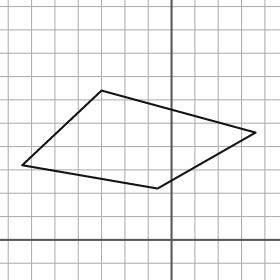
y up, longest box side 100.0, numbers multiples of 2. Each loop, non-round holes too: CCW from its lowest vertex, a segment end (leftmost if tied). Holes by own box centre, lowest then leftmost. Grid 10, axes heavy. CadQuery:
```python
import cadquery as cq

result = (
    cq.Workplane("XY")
    .moveTo(-6.0, 22.0)
    .lineTo(36.0, 46.0)
    .lineTo(-30.0, 64.0)
    .lineTo(-64.0, 32.0)
    .close()
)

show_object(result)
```